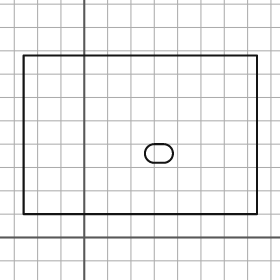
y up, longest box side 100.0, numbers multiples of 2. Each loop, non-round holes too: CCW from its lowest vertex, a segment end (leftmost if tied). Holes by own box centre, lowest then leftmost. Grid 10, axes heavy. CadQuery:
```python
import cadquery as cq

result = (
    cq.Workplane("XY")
    .moveTo(-26.0, 10.0)
    .lineTo(74.0, 10.0)
    .lineTo(74.0, 78.0)
    .lineTo(-26.0, 78.0)
    .close()
    .moveTo(30.0, 32.0)
    .lineTo(34.0, 32.0)
    .threePointArc((38.0, 36.0), (34.0, 40.0))
    .lineTo(30.0, 40.0)
    .threePointArc((26.0, 36.0), (30.0, 32.0))
    .close()
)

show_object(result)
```